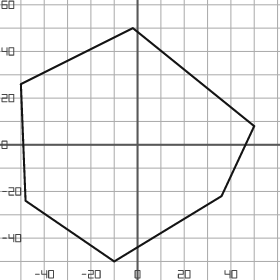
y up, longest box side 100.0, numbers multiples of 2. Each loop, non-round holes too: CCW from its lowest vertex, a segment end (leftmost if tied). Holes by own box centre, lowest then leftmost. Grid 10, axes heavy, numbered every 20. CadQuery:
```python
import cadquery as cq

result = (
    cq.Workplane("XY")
    .moveTo(-10.0, -50.0)
    .lineTo(36.0, -22.0)
    .lineTo(50.0, 8.0)
    .lineTo(-2.0, 50.0)
    .lineTo(-50.0, 26.0)
    .lineTo(-48.0, -24.0)
    .close()
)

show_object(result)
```